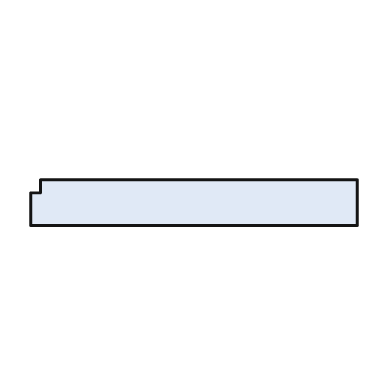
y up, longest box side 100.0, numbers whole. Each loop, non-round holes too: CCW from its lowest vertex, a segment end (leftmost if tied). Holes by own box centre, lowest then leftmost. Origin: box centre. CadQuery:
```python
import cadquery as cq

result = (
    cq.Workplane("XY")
    .moveTo(-50.0, -7.0)
    .lineTo(50.0, -7.0)
    .lineTo(50.0, 7.0)
    .lineTo(-47.0, 7.0)
    .lineTo(-47.0, 3.0)
    .lineTo(-50.0, 3.0)
    .close()
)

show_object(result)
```